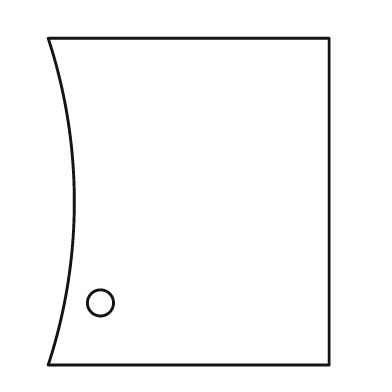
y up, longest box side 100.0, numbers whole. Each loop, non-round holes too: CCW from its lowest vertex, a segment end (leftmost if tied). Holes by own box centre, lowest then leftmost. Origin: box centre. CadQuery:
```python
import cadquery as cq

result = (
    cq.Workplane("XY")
    .moveTo(-43.0, -50.0)
    .lineTo(43.0, -50.0)
    .lineTo(43.0, 50.0)
    .lineTo(-43.0, 50.0)
    .threePointArc((-35.0, 0.0), (-43.0, -50.0))
    .close()
    .moveTo(-27.0, -31.0)
    .circle(4.0)
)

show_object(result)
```